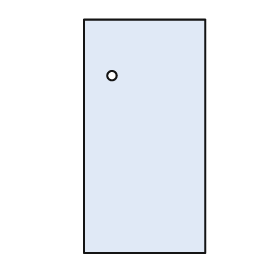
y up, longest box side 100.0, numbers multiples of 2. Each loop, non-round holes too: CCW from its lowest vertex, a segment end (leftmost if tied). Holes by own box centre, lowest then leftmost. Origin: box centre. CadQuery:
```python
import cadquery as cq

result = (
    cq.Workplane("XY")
    .moveTo(-26.0, -50.0)
    .lineTo(26.0, -50.0)
    .lineTo(26.0, 50.0)
    .lineTo(-26.0, 50.0)
    .close()
    .moveTo(-14.0, 26.0)
    .circle(2.0)
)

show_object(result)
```